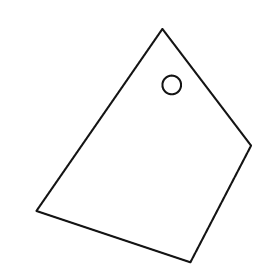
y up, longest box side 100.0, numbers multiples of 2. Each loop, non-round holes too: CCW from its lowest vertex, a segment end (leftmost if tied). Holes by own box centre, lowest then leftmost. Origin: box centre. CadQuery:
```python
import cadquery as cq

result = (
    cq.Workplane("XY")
    .moveTo(20.0, -50.0)
    .lineTo(46.0, 0.0)
    .lineTo(8.0, 50.0)
    .lineTo(-46.0, -28.0)
    .close()
    .moveTo(12.0, 26.0)
    .circle(4.0)
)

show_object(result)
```